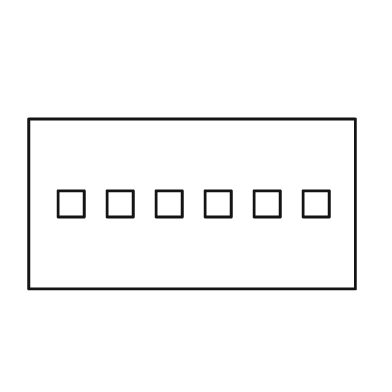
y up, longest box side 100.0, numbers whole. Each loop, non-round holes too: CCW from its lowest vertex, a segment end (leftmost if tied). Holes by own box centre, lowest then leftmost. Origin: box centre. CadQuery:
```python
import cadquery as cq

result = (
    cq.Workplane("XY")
    .moveTo(-50.0, -26.0)
    .lineTo(50.0, -26.0)
    .lineTo(50.0, 26.0)
    .lineTo(-50.0, 26.0)
    .close()
    .moveTo(-41.0, -4.0)
    .lineTo(-33.0, -4.0)
    .lineTo(-33.0, 4.0)
    .lineTo(-41.0, 4.0)
    .close()
    .moveTo(-26.0, -4.0)
    .lineTo(-18.0, -4.0)
    .lineTo(-18.0, 4.0)
    .lineTo(-26.0, 4.0)
    .close()
    .moveTo(-11.0, -4.0)
    .lineTo(-3.0, -4.0)
    .lineTo(-3.0, 4.0)
    .lineTo(-11.0, 4.0)
    .close()
    .moveTo(4.0, -4.0)
    .lineTo(12.0, -4.0)
    .lineTo(12.0, 4.0)
    .lineTo(4.0, 4.0)
    .close()
    .moveTo(19.0, -4.0)
    .lineTo(27.0, -4.0)
    .lineTo(27.0, 4.0)
    .lineTo(19.0, 4.0)
    .close()
    .moveTo(34.0, -4.0)
    .lineTo(42.0, -4.0)
    .lineTo(42.0, 4.0)
    .lineTo(34.0, 4.0)
    .close()
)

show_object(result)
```